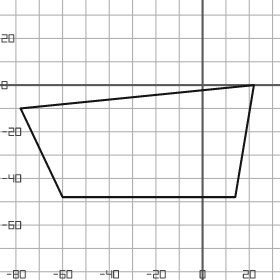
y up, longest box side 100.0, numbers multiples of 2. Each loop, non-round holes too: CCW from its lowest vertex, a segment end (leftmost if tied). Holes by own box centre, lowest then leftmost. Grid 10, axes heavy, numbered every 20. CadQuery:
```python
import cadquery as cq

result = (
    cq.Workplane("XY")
    .moveTo(-60.0, -48.0)
    .lineTo(14.0, -48.0)
    .lineTo(22.0, 0.0)
    .lineTo(-78.0, -10.0)
    .close()
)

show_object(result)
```